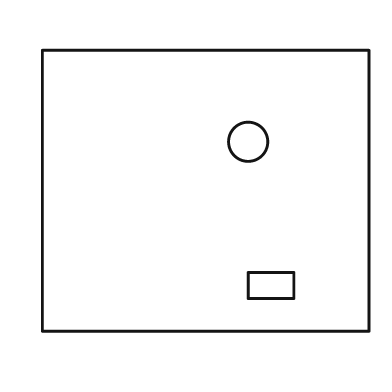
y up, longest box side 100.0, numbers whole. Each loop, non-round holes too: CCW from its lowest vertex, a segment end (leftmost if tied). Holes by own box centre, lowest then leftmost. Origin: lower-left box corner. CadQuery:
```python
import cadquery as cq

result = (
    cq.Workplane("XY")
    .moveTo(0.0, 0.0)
    .lineTo(100.0, 0.0)
    .lineTo(100.0, 86.0)
    .lineTo(0.0, 86.0)
    .close()
    .moveTo(63.0, 10.0)
    .lineTo(77.0, 10.0)
    .lineTo(77.0, 18.0)
    .lineTo(63.0, 18.0)
    .close()
    .moveTo(63.0, 58.0)
    .circle(6.0)
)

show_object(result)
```